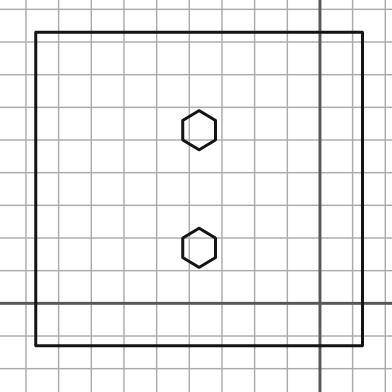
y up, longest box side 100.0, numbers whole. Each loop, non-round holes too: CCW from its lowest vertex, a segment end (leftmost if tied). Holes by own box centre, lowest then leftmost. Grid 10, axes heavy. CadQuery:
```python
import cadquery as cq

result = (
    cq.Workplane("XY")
    .moveTo(-87.0, -13.0)
    .lineTo(13.0, -13.0)
    .lineTo(13.0, 83.0)
    .lineTo(-87.0, 83.0)
    .close()
    .moveTo(-37.0, 11.0)
    .lineTo(-32.0, 14.0)
    .lineTo(-32.0, 20.0)
    .lineTo(-37.0, 23.0)
    .lineTo(-42.0, 20.0)
    .lineTo(-42.0, 14.0)
    .close()
    .moveTo(-37.0, 47.0)
    .lineTo(-32.0, 50.0)
    .lineTo(-32.0, 56.0)
    .lineTo(-37.0, 59.0)
    .lineTo(-42.0, 56.0)
    .lineTo(-42.0, 50.0)
    .close()
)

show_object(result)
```